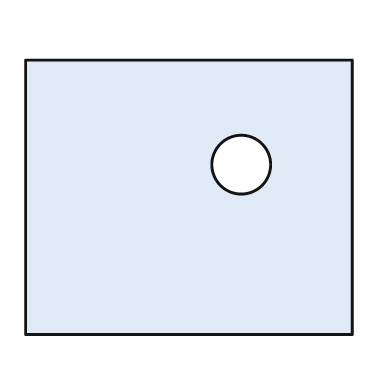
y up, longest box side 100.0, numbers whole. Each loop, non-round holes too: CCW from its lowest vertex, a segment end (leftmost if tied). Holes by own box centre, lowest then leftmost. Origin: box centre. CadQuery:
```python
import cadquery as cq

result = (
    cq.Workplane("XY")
    .moveTo(-50.0, -42.0)
    .lineTo(50.0, -42.0)
    .lineTo(50.0, 42.0)
    .lineTo(-50.0, 42.0)
    .close()
    .moveTo(16.0, 10.0)
    .circle(9.0)
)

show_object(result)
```